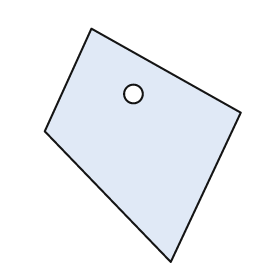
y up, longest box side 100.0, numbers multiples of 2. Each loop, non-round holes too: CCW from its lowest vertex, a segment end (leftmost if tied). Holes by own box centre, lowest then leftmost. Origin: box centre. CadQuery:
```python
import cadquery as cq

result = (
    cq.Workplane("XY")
    .moveTo(12.0, -50.0)
    .lineTo(42.0, 14.0)
    .lineTo(-22.0, 50.0)
    .lineTo(-42.0, 6.0)
    .close()
    .moveTo(-4.0, 22.0)
    .circle(4.0)
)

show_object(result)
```